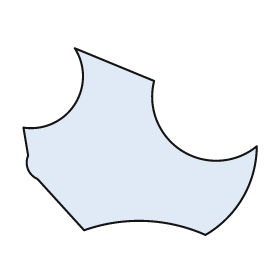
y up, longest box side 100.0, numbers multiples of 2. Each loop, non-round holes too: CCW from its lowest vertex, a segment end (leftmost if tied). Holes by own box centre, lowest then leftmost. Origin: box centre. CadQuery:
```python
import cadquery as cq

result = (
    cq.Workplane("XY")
    .moveTo(28.0, -40.0)
    .threePointArc((44.0, -24.0), (50.0, -2.0))
    .threePointArc((18.0, -4.0), (6.0, 26.0))
    .lineTo(-28.0, 40.0)
    .threePointArc((-28.0, 16.0), (-50.0, 6.0))
    .lineTo(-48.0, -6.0)
    .threePointArc((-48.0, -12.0), (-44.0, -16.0))
    .lineTo(-24.0, -38.0)
    .threePointArc((2.0, -34.0), (28.0, -40.0))
    .close()
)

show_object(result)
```